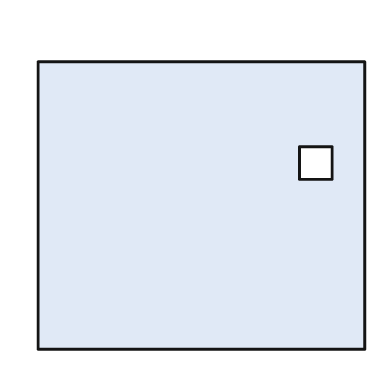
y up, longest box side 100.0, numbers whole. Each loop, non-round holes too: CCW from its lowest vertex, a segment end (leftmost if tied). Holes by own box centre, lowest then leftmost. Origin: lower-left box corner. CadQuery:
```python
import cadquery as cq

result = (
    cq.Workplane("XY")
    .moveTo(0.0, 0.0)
    .lineTo(100.0, 0.0)
    .lineTo(100.0, 88.0)
    .lineTo(0.0, 88.0)
    .close()
    .moveTo(80.0, 52.0)
    .lineTo(90.0, 52.0)
    .lineTo(90.0, 62.0)
    .lineTo(80.0, 62.0)
    .close()
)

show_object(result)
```